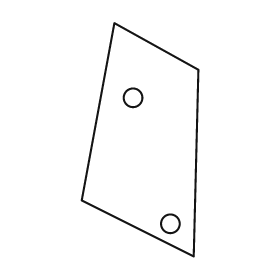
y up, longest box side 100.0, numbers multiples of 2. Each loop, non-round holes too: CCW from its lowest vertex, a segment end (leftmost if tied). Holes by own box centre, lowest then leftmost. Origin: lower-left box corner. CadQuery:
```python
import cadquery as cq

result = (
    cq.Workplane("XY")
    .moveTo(48.0, 0.0)
    .lineTo(50.0, 80.0)
    .lineTo(14.0, 100.0)
    .lineTo(0.0, 24.0)
    .close()
    .moveTo(38.0, 14.0)
    .circle(4.0)
    .moveTo(22.0, 68.0)
    .circle(4.0)
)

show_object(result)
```